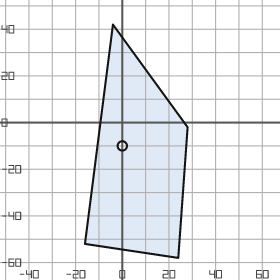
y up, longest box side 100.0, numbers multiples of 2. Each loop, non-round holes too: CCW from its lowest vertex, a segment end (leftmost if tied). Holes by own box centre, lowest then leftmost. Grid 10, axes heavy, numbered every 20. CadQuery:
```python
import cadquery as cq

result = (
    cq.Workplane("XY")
    .moveTo(24.0, -58.0)
    .lineTo(28.0, -2.0)
    .lineTo(-4.0, 42.0)
    .lineTo(-16.0, -52.0)
    .close()
    .moveTo(0.0, -10.0)
    .circle(2.0)
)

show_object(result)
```